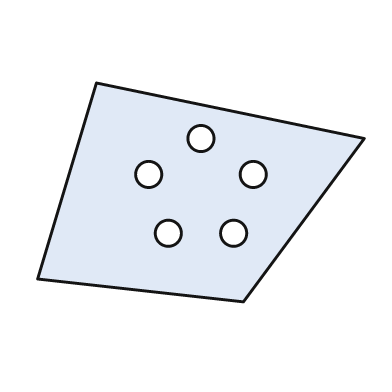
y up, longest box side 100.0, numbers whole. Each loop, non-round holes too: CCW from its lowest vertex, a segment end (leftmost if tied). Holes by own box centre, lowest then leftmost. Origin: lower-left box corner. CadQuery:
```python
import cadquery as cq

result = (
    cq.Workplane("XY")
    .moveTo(63.0, 0.0)
    .lineTo(100.0, 50.0)
    .lineTo(18.0, 67.0)
    .lineTo(0.0, 7.0)
    .close()
    .moveTo(40.0, 21.0)
    .circle(4.0)
    .moveTo(60.0, 21.0)
    .circle(4.0)
    .moveTo(34.0, 39.0)
    .circle(4.0)
    .moveTo(66.0, 39.0)
    .circle(4.0)
    .moveTo(50.0, 50.0)
    .circle(4.0)
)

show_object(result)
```